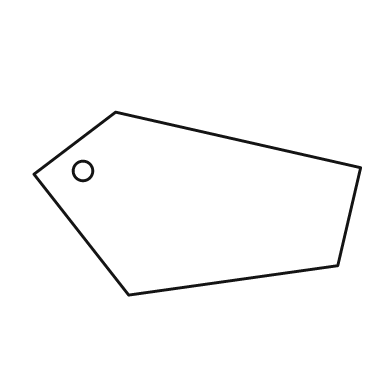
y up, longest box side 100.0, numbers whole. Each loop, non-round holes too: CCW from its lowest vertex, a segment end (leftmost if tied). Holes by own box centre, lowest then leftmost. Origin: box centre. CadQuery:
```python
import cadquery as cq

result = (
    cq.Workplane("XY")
    .moveTo(-21.0, -28.0)
    .lineTo(43.0, -19.0)
    .lineTo(50.0, 11.0)
    .lineTo(-25.0, 28.0)
    .lineTo(-50.0, 9.0)
    .close()
    .moveTo(-35.0, 10.0)
    .circle(3.0)
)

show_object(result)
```